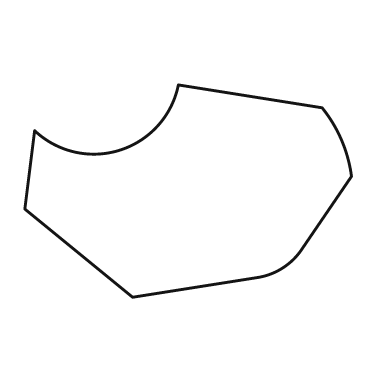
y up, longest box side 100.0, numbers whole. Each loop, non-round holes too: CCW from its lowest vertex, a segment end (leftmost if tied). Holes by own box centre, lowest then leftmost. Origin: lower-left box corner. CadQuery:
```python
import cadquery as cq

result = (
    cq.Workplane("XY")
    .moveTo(33.0, 0.0)
    .lineTo(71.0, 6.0)
    .threePointArc((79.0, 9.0), (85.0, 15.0))
    .lineTo(100.0, 37.0)
    .threePointArc((97.0, 48.0), (91.0, 58.0))
    .lineTo(47.0, 65.0)
    .threePointArc((29.0, 45.0), (3.0, 51.0))
    .lineTo(0.0, 27.0)
    .close()
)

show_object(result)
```